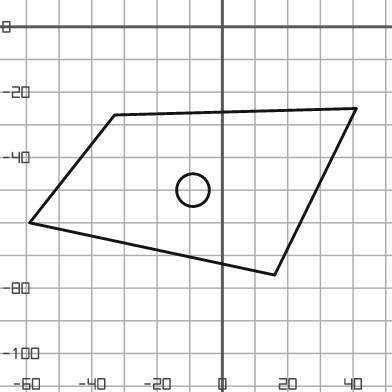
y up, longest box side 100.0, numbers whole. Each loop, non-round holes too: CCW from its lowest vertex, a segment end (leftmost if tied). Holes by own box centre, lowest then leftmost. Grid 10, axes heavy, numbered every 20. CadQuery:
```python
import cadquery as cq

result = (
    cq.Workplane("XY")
    .moveTo(16.0, -76.0)
    .lineTo(41.0, -25.0)
    .lineTo(-33.0, -27.0)
    .lineTo(-59.0, -60.0)
    .close()
    .moveTo(-9.0, -50.0)
    .circle(5.0)
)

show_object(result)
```